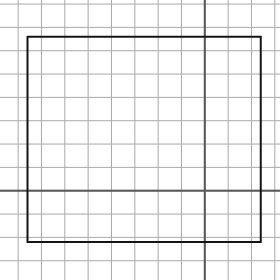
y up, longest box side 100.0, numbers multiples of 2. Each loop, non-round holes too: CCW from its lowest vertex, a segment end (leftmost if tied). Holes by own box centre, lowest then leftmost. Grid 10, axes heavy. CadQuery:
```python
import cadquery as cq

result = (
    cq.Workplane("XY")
    .moveTo(-76.0, -22.0)
    .lineTo(24.0, -22.0)
    .lineTo(24.0, 66.0)
    .lineTo(-76.0, 66.0)
    .close()
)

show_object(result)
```